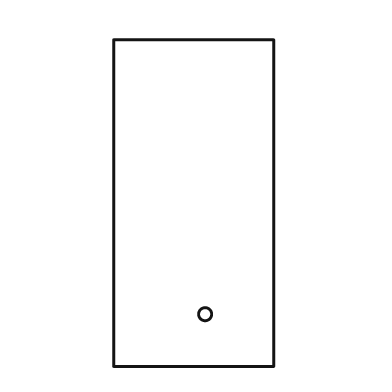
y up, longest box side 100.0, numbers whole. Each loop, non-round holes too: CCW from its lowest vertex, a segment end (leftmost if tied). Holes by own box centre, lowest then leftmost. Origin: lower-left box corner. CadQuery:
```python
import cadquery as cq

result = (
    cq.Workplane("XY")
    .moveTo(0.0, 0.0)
    .lineTo(49.0, 0.0)
    .lineTo(49.0, 100.0)
    .lineTo(0.0, 100.0)
    .close()
    .moveTo(28.0, 16.0)
    .circle(2.0)
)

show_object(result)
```